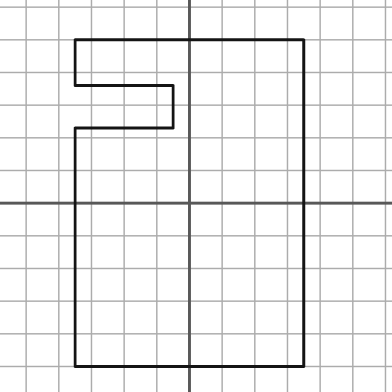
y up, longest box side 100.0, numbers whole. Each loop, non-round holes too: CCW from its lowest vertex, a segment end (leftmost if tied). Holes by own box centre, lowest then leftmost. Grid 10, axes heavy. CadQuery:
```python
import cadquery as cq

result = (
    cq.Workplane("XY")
    .moveTo(-35.0, -50.0)
    .lineTo(35.0, -50.0)
    .lineTo(35.0, 50.0)
    .lineTo(-35.0, 50.0)
    .lineTo(-35.0, 36.0)
    .lineTo(-5.0, 36.0)
    .lineTo(-5.0, 23.0)
    .lineTo(-35.0, 23.0)
    .close()
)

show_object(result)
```